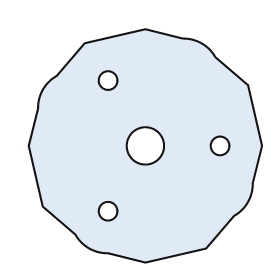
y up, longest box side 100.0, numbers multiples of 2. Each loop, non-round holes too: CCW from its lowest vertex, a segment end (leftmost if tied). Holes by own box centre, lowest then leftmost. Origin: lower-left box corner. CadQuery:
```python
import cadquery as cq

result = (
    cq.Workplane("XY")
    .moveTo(50.0, 0.0)
    .lineTo(76.0, 6.0)
    .lineTo(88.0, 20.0)
    .threePointArc((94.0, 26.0), (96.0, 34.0))
    .lineTo(100.0, 50.0)
    .lineTo(94.0, 76.0)
    .lineTo(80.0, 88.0)
    .threePointArc((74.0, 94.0), (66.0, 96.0))
    .lineTo(50.0, 100.0)
    .lineTo(24.0, 94.0)
    .lineTo(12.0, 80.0)
    .threePointArc((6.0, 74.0), (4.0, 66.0))
    .lineTo(0.0, 50.0)
    .lineTo(6.0, 24.0)
    .lineTo(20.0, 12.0)
    .threePointArc((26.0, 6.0), (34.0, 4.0))
    .close()
    .moveTo(34.0, 22.0)
    .circle(4.0)
    .moveTo(50.0, 50.0)
    .circle(8.0)
    .moveTo(82.0, 50.0)
    .circle(4.0)
    .moveTo(34.0, 78.0)
    .circle(4.0)
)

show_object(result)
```